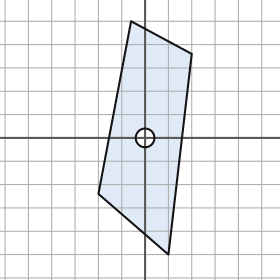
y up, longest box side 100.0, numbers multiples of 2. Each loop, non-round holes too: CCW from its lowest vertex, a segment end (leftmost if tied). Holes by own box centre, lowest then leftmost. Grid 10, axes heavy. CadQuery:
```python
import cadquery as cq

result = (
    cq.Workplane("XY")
    .moveTo(10.0, -50.0)
    .lineTo(20.0, 36.0)
    .lineTo(-6.0, 50.0)
    .lineTo(-20.0, -24.0)
    .close()
    .moveTo(0.0, 0.0)
    .circle(4.0)
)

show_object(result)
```